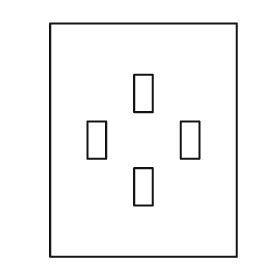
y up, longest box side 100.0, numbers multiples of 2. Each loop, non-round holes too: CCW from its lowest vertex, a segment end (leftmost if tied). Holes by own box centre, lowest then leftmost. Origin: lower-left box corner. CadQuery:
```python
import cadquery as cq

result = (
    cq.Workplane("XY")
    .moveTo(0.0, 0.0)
    .lineTo(80.0, 0.0)
    .lineTo(80.0, 100.0)
    .lineTo(0.0, 100.0)
    .close()
    .moveTo(36.0, 22.0)
    .lineTo(44.0, 22.0)
    .lineTo(44.0, 38.0)
    .lineTo(36.0, 38.0)
    .close()
    .moveTo(16.0, 42.0)
    .lineTo(24.0, 42.0)
    .lineTo(24.0, 58.0)
    .lineTo(16.0, 58.0)
    .close()
    .moveTo(56.0, 42.0)
    .lineTo(64.0, 42.0)
    .lineTo(64.0, 58.0)
    .lineTo(56.0, 58.0)
    .close()
    .moveTo(36.0, 62.0)
    .lineTo(44.0, 62.0)
    .lineTo(44.0, 78.0)
    .lineTo(36.0, 78.0)
    .close()
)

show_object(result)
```